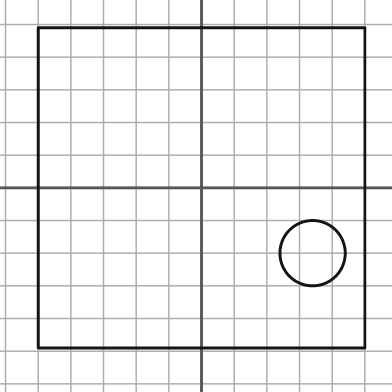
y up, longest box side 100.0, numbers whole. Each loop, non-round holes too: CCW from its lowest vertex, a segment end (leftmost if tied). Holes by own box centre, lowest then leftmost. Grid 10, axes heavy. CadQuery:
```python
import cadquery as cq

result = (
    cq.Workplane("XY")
    .moveTo(-50.0, -49.0)
    .lineTo(50.0, -49.0)
    .lineTo(50.0, 49.0)
    .lineTo(-50.0, 49.0)
    .close()
    .moveTo(34.0, -20.0)
    .circle(10.0)
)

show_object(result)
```